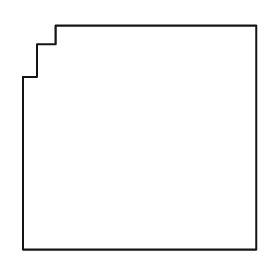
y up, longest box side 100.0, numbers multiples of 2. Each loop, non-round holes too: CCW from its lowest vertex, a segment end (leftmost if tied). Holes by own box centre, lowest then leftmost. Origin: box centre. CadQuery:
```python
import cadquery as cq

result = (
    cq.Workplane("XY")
    .moveTo(-50.0, -48.0)
    .lineTo(50.0, -48.0)
    .lineTo(50.0, 48.0)
    .lineTo(-36.0, 48.0)
    .lineTo(-36.0, 40.0)
    .lineTo(-44.0, 40.0)
    .lineTo(-44.0, 26.0)
    .lineTo(-50.0, 26.0)
    .close()
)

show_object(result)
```